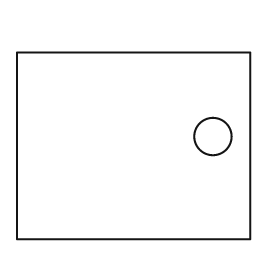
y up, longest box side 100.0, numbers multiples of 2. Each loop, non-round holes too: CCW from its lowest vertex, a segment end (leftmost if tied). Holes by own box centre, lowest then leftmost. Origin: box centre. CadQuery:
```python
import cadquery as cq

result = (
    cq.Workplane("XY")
    .moveTo(-50.0, -40.0)
    .lineTo(50.0, -40.0)
    .lineTo(50.0, 40.0)
    .lineTo(-50.0, 40.0)
    .close()
    .moveTo(34.0, 4.0)
    .circle(8.0)
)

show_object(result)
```